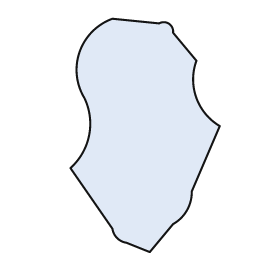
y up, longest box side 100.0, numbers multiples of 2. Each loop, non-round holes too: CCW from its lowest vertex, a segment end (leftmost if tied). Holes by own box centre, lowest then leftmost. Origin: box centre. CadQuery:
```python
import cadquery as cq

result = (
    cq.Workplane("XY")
    .moveTo(2.0, -50.0)
    .lineTo(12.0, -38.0)
    .threePointArc((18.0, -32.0), (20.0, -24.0))
    .lineTo(32.0, 4.0)
    .threePointArc((22.0, 16.0), (22.0, 32.0))
    .lineTo(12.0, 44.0)
    .threePointArc((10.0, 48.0), (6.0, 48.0))
    .lineTo(-14.0, 50.0)
    .threePointArc((-28.0, 36.0), (-26.0, 16.0))
    .threePointArc((-24.0, 0.0), (-32.0, -14.0))
    .lineTo(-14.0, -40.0)
    .threePointArc((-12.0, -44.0), (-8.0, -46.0))
    .close()
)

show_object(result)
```